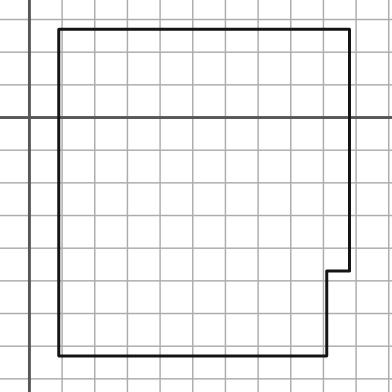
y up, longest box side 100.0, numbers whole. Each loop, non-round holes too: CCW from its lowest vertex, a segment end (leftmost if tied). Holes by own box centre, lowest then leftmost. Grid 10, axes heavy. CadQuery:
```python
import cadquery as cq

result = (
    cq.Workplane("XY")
    .moveTo(9.0, -73.0)
    .lineTo(91.0, -73.0)
    .lineTo(91.0, -47.0)
    .lineTo(98.0, -47.0)
    .lineTo(98.0, 27.0)
    .lineTo(9.0, 27.0)
    .close()
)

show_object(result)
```